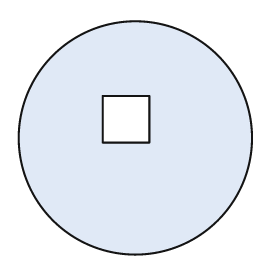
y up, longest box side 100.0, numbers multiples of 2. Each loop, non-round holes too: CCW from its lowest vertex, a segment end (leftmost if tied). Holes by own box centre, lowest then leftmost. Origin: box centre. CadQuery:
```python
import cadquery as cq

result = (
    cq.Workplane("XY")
    .moveTo(0.0, 0.0)
    .circle(50.0)
    .moveTo(-14.0, -2.0)
    .lineTo(6.0, -2.0)
    .lineTo(6.0, 18.0)
    .lineTo(-14.0, 18.0)
    .close()
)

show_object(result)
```